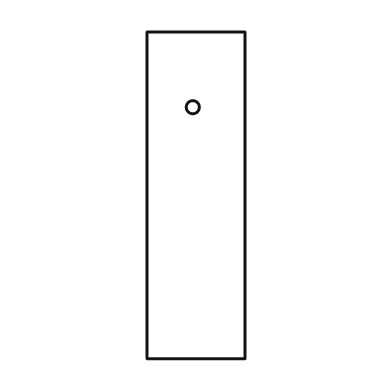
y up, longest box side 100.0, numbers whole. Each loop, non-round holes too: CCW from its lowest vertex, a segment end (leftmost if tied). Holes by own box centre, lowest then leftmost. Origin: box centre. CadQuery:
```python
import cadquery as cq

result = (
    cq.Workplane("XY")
    .moveTo(-15.0, -50.0)
    .lineTo(15.0, -50.0)
    .lineTo(15.0, 50.0)
    .lineTo(-15.0, 50.0)
    .close()
    .moveTo(-1.0, 27.0)
    .circle(2.0)
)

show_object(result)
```